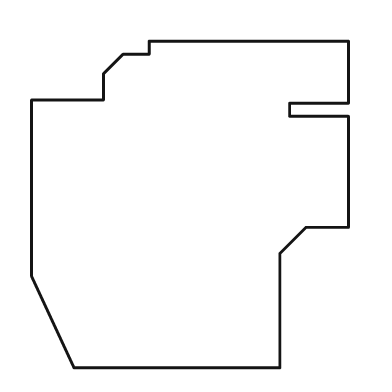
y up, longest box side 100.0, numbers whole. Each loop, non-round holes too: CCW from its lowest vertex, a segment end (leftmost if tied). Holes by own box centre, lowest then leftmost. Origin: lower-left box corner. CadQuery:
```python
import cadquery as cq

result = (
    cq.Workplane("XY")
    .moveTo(13.0, 0.0)
    .lineTo(76.0, 0.0)
    .lineTo(76.0, 35.0)
    .lineTo(84.0, 43.0)
    .lineTo(97.0, 43.0)
    .lineTo(97.0, 77.0)
    .lineTo(79.0, 77.0)
    .lineTo(79.0, 81.0)
    .lineTo(97.0, 81.0)
    .lineTo(97.0, 100.0)
    .lineTo(36.0, 100.0)
    .lineTo(36.0, 96.0)
    .lineTo(28.0, 96.0)
    .lineTo(22.0, 90.0)
    .lineTo(22.0, 82.0)
    .lineTo(0.0, 82.0)
    .lineTo(0.0, 28.0)
    .close()
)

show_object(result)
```